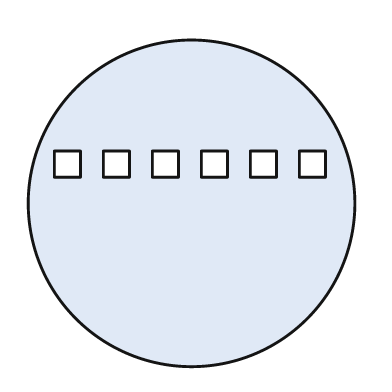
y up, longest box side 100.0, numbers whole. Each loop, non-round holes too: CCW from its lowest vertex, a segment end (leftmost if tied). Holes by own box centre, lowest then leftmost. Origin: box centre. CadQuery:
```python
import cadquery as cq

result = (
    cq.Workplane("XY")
    .moveTo(0.0, 0.0)
    .circle(50.0)
    .moveTo(-42.0, 8.0)
    .lineTo(-34.0, 8.0)
    .lineTo(-34.0, 16.0)
    .lineTo(-42.0, 16.0)
    .close()
    .moveTo(-27.0, 8.0)
    .lineTo(-19.0, 8.0)
    .lineTo(-19.0, 16.0)
    .lineTo(-27.0, 16.0)
    .close()
    .moveTo(-12.0, 8.0)
    .lineTo(-4.0, 8.0)
    .lineTo(-4.0, 16.0)
    .lineTo(-12.0, 16.0)
    .close()
    .moveTo(3.0, 8.0)
    .lineTo(11.0, 8.0)
    .lineTo(11.0, 16.0)
    .lineTo(3.0, 16.0)
    .close()
    .moveTo(18.0, 8.0)
    .lineTo(26.0, 8.0)
    .lineTo(26.0, 16.0)
    .lineTo(18.0, 16.0)
    .close()
    .moveTo(33.0, 8.0)
    .lineTo(41.0, 8.0)
    .lineTo(41.0, 16.0)
    .lineTo(33.0, 16.0)
    .close()
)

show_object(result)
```